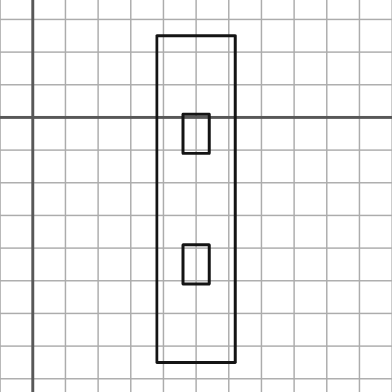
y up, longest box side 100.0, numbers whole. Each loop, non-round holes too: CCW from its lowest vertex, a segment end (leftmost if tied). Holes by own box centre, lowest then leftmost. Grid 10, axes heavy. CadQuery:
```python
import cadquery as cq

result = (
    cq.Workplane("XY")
    .moveTo(38.0, -75.0)
    .lineTo(62.0, -75.0)
    .lineTo(62.0, 25.0)
    .lineTo(38.0, 25.0)
    .close()
    .moveTo(46.0, -51.0)
    .lineTo(54.0, -51.0)
    .lineTo(54.0, -39.0)
    .lineTo(46.0, -39.0)
    .close()
    .moveTo(46.0, -11.0)
    .lineTo(54.0, -11.0)
    .lineTo(54.0, 1.0)
    .lineTo(46.0, 1.0)
    .close()
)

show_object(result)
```